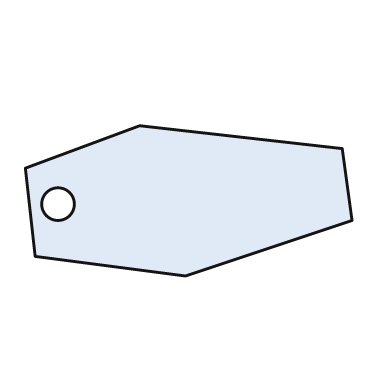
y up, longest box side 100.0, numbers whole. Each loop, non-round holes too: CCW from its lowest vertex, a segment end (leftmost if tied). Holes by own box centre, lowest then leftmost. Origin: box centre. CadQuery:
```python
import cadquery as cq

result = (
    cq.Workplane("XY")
    .moveTo(-1.0, -23.0)
    .lineTo(50.0, -6.0)
    .lineTo(47.0, 16.0)
    .lineTo(-15.0, 23.0)
    .lineTo(-50.0, 10.0)
    .lineTo(-47.0, -17.0)
    .close()
    .moveTo(-40.0, -1.0)
    .circle(5.0)
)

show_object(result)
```